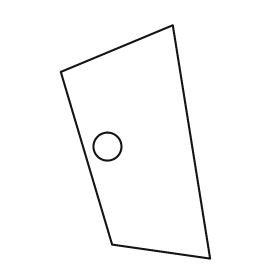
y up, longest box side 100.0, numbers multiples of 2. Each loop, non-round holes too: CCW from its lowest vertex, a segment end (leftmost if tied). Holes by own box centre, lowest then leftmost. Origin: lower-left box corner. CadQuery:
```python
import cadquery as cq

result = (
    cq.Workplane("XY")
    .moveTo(64.0, 0.0)
    .lineTo(48.0, 100.0)
    .lineTo(0.0, 80.0)
    .lineTo(22.0, 6.0)
    .close()
    .moveTo(20.0, 48.0)
    .circle(6.0)
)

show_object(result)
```